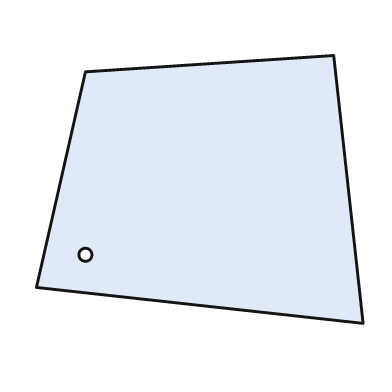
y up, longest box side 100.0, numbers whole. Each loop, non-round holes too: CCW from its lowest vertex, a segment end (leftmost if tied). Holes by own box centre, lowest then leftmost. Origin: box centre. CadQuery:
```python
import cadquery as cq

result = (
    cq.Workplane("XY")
    .moveTo(50.0, -41.0)
    .lineTo(41.0, 41.0)
    .lineTo(-35.0, 36.0)
    .lineTo(-50.0, -30.0)
    .close()
    .moveTo(-35.0, -20.0)
    .circle(2.0)
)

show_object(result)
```